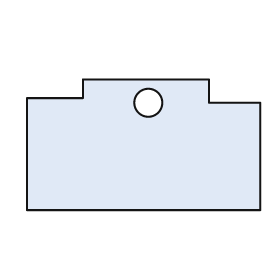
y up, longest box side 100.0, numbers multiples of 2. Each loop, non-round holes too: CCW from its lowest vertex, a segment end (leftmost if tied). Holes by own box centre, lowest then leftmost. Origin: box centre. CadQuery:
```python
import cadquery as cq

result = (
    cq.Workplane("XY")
    .moveTo(-50.0, -28.0)
    .lineTo(50.0, -28.0)
    .lineTo(50.0, 18.0)
    .lineTo(28.0, 18.0)
    .lineTo(28.0, 28.0)
    .lineTo(-26.0, 28.0)
    .lineTo(-26.0, 20.0)
    .lineTo(-50.0, 20.0)
    .close()
    .moveTo(2.0, 18.0)
    .circle(6.0)
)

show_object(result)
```